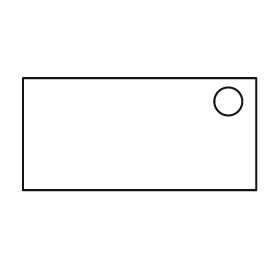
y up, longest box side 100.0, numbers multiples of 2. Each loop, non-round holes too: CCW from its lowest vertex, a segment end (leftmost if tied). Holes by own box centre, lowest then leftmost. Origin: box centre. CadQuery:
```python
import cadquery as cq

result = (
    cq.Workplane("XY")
    .moveTo(-50.0, -24.0)
    .lineTo(50.0, -24.0)
    .lineTo(50.0, 24.0)
    .lineTo(-50.0, 24.0)
    .close()
    .moveTo(38.0, 14.0)
    .circle(6.0)
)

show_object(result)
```